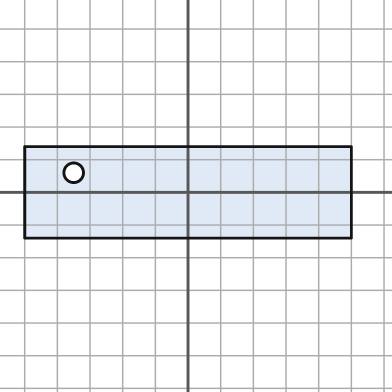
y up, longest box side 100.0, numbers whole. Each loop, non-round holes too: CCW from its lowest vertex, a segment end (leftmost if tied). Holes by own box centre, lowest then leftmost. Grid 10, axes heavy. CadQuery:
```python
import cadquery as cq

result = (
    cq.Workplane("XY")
    .moveTo(-50.0, -14.0)
    .lineTo(50.0, -14.0)
    .lineTo(50.0, 14.0)
    .lineTo(-50.0, 14.0)
    .close()
    .moveTo(-35.0, 6.0)
    .circle(3.0)
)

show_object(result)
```